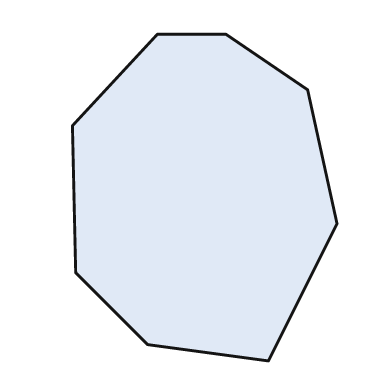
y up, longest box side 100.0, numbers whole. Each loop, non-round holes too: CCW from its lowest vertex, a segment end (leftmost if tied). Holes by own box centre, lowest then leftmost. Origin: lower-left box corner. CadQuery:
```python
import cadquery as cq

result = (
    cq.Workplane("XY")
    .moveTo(60.0, 0.0)
    .lineTo(81.0, 42.0)
    .lineTo(72.0, 83.0)
    .lineTo(47.0, 100.0)
    .lineTo(26.0, 100.0)
    .lineTo(0.0, 72.0)
    .lineTo(1.0, 27.0)
    .lineTo(23.0, 5.0)
    .close()
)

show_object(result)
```